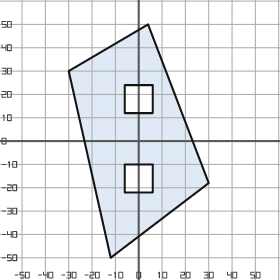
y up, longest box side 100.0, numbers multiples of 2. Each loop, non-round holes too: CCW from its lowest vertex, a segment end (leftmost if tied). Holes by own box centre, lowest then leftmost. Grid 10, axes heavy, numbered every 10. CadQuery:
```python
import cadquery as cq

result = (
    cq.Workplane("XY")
    .moveTo(-12.0, -50.0)
    .lineTo(30.0, -18.0)
    .lineTo(4.0, 50.0)
    .lineTo(-30.0, 30.0)
    .close()
    .moveTo(-6.0, -22.0)
    .lineTo(6.0, -22.0)
    .lineTo(6.0, -10.0)
    .lineTo(-6.0, -10.0)
    .close()
    .moveTo(-6.0, 12.0)
    .lineTo(6.0, 12.0)
    .lineTo(6.0, 24.0)
    .lineTo(-6.0, 24.0)
    .close()
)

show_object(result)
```